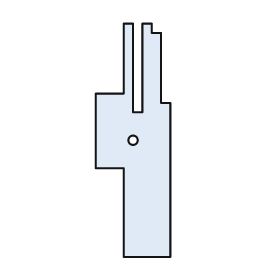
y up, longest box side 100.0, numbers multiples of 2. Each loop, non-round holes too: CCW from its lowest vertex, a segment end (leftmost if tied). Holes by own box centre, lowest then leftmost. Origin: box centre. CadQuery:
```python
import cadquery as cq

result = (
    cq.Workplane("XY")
    .moveTo(-4.0, -50.0)
    .lineTo(16.0, -50.0)
    .lineTo(16.0, 16.0)
    .lineTo(12.0, 16.0)
    .lineTo(12.0, 46.0)
    .lineTo(8.0, 46.0)
    .lineTo(8.0, 50.0)
    .lineTo(4.0, 50.0)
    .lineTo(4.0, 12.0)
    .lineTo(0.0, 12.0)
    .lineTo(0.0, 50.0)
    .lineTo(-4.0, 50.0)
    .lineTo(-4.0, 20.0)
    .lineTo(-16.0, 20.0)
    .lineTo(-16.0, -12.0)
    .lineTo(-4.0, -12.0)
    .close()
    .moveTo(0.0, 0.0)
    .circle(2.0)
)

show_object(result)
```